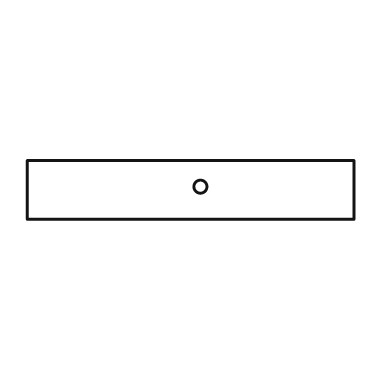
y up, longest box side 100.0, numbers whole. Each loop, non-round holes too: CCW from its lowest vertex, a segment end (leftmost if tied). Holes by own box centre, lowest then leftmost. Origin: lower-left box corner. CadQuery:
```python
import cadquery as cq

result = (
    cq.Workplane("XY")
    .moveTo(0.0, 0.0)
    .lineTo(100.0, 0.0)
    .lineTo(100.0, 18.0)
    .lineTo(0.0, 18.0)
    .close()
    .moveTo(53.0, 10.0)
    .circle(2.0)
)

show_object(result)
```